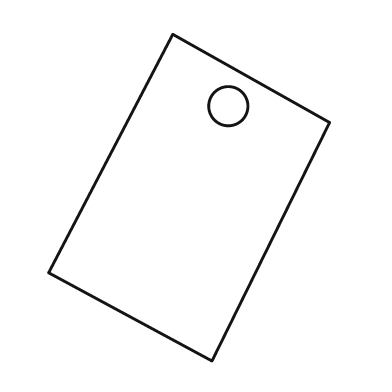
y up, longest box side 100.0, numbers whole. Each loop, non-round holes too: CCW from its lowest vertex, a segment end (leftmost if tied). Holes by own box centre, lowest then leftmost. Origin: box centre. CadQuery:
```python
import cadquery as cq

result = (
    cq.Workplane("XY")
    .moveTo(7.0, -50.0)
    .lineTo(43.0, 23.0)
    .lineTo(-5.0, 50.0)
    .lineTo(-43.0, -23.0)
    .close()
    .moveTo(12.0, 28.0)
    .circle(6.0)
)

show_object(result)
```